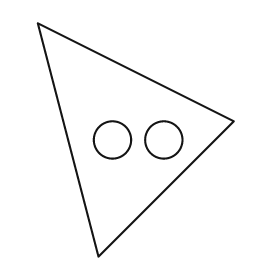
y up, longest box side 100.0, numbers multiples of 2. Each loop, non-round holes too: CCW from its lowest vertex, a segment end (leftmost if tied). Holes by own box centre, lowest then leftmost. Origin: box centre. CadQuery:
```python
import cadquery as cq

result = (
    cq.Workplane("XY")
    .moveTo(-16.0, -50.0)
    .lineTo(42.0, 8.0)
    .lineTo(-42.0, 50.0)
    .close()
    .moveTo(-10.0, 0.0)
    .circle(8.0)
    .moveTo(12.0, 0.0)
    .circle(8.0)
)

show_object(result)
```